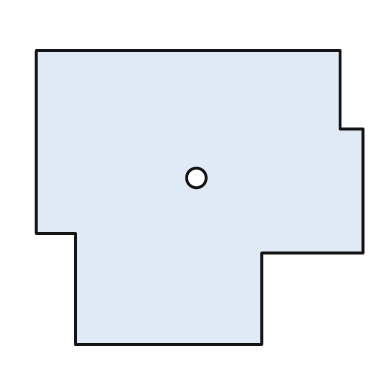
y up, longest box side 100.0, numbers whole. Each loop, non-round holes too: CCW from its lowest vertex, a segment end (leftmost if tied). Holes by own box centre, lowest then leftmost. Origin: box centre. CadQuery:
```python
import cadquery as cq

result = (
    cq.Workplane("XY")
    .moveTo(-38.0, -45.0)
    .lineTo(19.0, -45.0)
    .lineTo(19.0, -17.0)
    .lineTo(50.0, -17.0)
    .lineTo(50.0, 21.0)
    .lineTo(43.0, 21.0)
    .lineTo(43.0, 45.0)
    .lineTo(-50.0, 45.0)
    .lineTo(-50.0, -11.0)
    .lineTo(-38.0, -11.0)
    .close()
    .moveTo(-1.0, 6.0)
    .circle(3.0)
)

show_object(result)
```